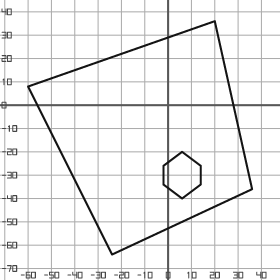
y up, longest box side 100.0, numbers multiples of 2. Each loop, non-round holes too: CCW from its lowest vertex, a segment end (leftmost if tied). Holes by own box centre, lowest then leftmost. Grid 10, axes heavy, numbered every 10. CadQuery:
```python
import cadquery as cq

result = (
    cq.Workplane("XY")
    .moveTo(-24.0, -64.0)
    .lineTo(36.0, -36.0)
    .lineTo(20.0, 36.0)
    .lineTo(-60.0, 8.0)
    .close()
    .moveTo(6.0, -40.0)
    .lineTo(14.0, -34.0)
    .lineTo(14.0, -26.0)
    .lineTo(6.0, -20.0)
    .lineTo(-2.0, -26.0)
    .lineTo(-2.0, -34.0)
    .close()
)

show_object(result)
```